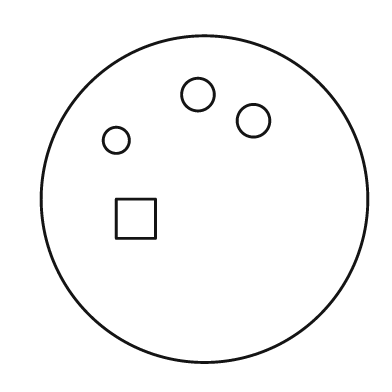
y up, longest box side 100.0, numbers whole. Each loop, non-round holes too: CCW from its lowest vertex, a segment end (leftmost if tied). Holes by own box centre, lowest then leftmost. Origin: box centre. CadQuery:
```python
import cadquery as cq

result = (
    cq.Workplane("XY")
    .moveTo(0.0, 0.0)
    .circle(50.0)
    .moveTo(-27.0, -12.0)
    .lineTo(-15.0, -12.0)
    .lineTo(-15.0, 0.0)
    .lineTo(-27.0, 0.0)
    .close()
    .moveTo(-27.0, 18.0)
    .circle(4.0)
    .moveTo(15.0, 24.0)
    .circle(5.0)
    .moveTo(-2.0, 32.0)
    .circle(5.0)
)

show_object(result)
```